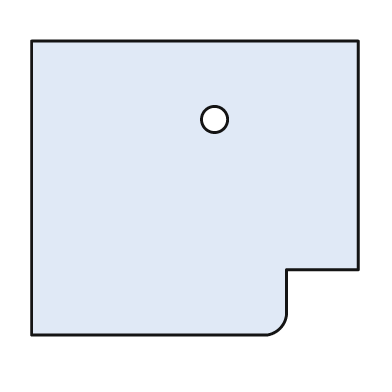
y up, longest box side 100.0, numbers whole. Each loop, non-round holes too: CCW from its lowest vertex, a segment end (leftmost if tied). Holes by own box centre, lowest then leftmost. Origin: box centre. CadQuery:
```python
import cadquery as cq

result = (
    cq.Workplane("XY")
    .moveTo(-50.0, -45.0)
    .lineTo(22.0, -45.0)
    .threePointArc((26.0, -43.0), (28.0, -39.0))
    .lineTo(28.0, -25.0)
    .lineTo(50.0, -25.0)
    .lineTo(50.0, 45.0)
    .lineTo(-50.0, 45.0)
    .close()
    .moveTo(6.0, 21.0)
    .circle(4.0)
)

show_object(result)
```